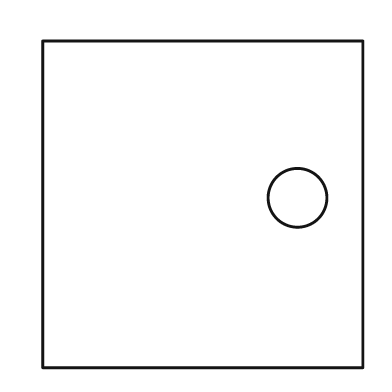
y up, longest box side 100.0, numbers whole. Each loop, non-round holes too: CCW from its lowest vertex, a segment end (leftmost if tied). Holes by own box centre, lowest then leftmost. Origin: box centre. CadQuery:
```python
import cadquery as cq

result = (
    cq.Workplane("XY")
    .moveTo(-49.0, -50.0)
    .lineTo(49.0, -50.0)
    .lineTo(49.0, 50.0)
    .lineTo(-49.0, 50.0)
    .close()
    .moveTo(29.0, 2.0)
    .circle(9.0)
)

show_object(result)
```